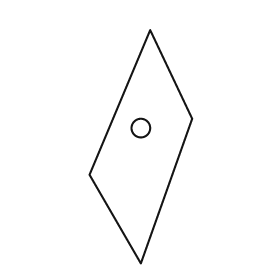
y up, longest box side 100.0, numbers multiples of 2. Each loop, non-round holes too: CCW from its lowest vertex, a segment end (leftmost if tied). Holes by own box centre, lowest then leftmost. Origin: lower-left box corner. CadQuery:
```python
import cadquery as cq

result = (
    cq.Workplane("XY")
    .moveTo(22.0, 0.0)
    .lineTo(44.0, 62.0)
    .lineTo(26.0, 100.0)
    .lineTo(0.0, 38.0)
    .close()
    .moveTo(22.0, 58.0)
    .circle(4.0)
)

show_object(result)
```